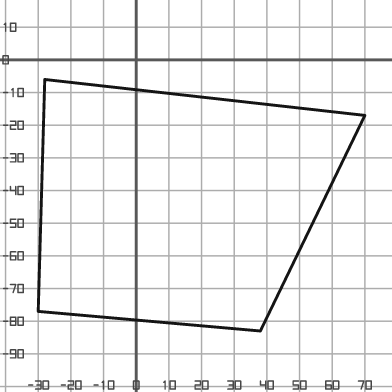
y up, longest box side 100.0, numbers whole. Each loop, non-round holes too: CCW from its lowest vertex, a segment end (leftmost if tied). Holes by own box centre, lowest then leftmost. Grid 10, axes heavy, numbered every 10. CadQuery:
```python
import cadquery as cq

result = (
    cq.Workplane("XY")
    .moveTo(38.0, -83.0)
    .lineTo(70.0, -17.0)
    .lineTo(-28.0, -6.0)
    .lineTo(-30.0, -77.0)
    .close()
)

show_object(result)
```